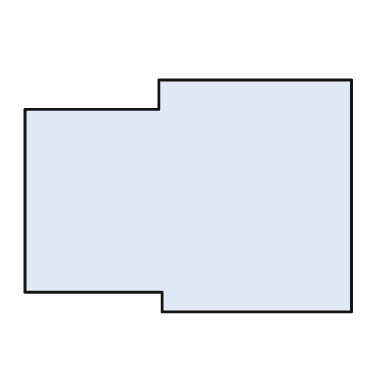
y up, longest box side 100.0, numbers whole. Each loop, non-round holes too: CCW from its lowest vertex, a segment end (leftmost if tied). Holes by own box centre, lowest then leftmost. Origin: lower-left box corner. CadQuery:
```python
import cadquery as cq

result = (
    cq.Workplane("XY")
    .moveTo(42.0, 0.0)
    .lineTo(100.0, 0.0)
    .lineTo(100.0, 71.0)
    .lineTo(41.0, 71.0)
    .lineTo(41.0, 62.0)
    .lineTo(0.0, 62.0)
    .lineTo(0.0, 6.0)
    .lineTo(42.0, 6.0)
    .close()
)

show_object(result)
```